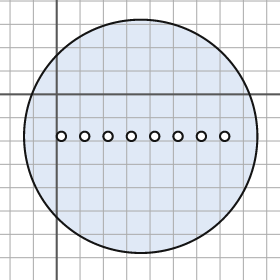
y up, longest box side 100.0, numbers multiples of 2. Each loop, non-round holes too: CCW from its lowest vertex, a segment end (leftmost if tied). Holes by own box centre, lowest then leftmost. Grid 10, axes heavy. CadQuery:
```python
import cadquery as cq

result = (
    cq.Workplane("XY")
    .moveTo(36.0, -18.0)
    .circle(50.0)
    .moveTo(2.0, -18.0)
    .circle(2.0)
    .moveTo(12.0, -18.0)
    .circle(2.0)
    .moveTo(22.0, -18.0)
    .circle(2.0)
    .moveTo(32.0, -18.0)
    .circle(2.0)
    .moveTo(42.0, -18.0)
    .circle(2.0)
    .moveTo(52.0, -18.0)
    .circle(2.0)
    .moveTo(62.0, -18.0)
    .circle(2.0)
    .moveTo(72.0, -18.0)
    .circle(2.0)
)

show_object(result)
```